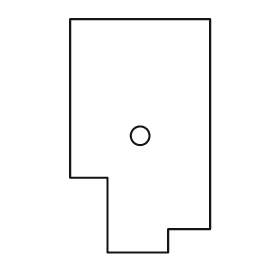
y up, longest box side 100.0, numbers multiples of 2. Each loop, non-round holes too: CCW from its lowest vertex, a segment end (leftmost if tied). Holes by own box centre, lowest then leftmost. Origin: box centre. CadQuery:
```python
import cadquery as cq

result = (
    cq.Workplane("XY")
    .moveTo(-14.0, -50.0)
    .lineTo(12.0, -50.0)
    .lineTo(12.0, -40.0)
    .lineTo(30.0, -40.0)
    .lineTo(30.0, 50.0)
    .lineTo(-30.0, 50.0)
    .lineTo(-30.0, -18.0)
    .lineTo(-14.0, -18.0)
    .close()
    .moveTo(0.0, 0.0)
    .circle(4.0)
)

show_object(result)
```